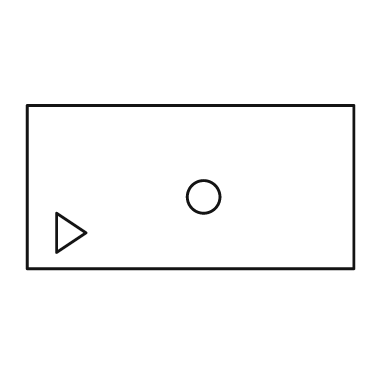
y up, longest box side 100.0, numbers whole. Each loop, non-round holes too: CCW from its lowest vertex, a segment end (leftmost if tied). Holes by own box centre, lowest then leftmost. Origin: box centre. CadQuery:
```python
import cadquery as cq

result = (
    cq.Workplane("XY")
    .moveTo(-50.0, -25.0)
    .lineTo(50.0, -25.0)
    .lineTo(50.0, 25.0)
    .lineTo(-50.0, 25.0)
    .close()
    .moveTo(-41.0, -20.0)
    .lineTo(-32.0, -14.0)
    .lineTo(-41.0, -8.0)
    .close()
    .moveTo(4.0, -3.0)
    .circle(5.0)
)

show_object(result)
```